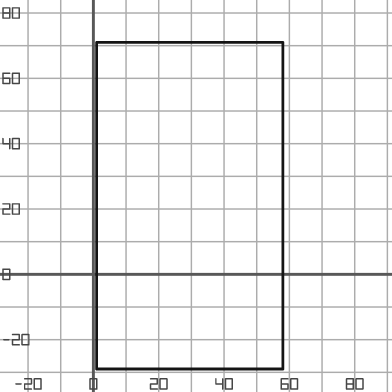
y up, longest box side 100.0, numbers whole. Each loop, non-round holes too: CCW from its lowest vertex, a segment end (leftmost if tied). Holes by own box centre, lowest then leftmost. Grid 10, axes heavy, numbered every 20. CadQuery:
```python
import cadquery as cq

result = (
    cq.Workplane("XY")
    .moveTo(1.0, -29.0)
    .lineTo(58.0, -29.0)
    .lineTo(58.0, 71.0)
    .lineTo(1.0, 71.0)
    .close()
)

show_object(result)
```